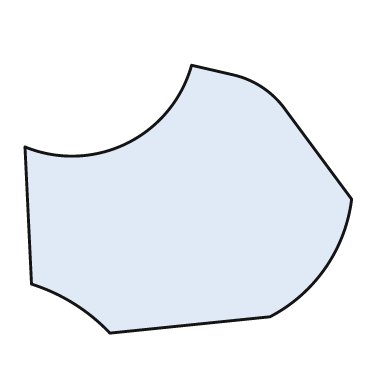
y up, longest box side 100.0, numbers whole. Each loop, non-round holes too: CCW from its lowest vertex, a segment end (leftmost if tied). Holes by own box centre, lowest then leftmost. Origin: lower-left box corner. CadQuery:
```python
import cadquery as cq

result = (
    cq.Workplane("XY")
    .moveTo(26.0, 0.0)
    .lineTo(75.0, 5.0)
    .threePointArc((92.0, 20.0), (100.0, 41.0))
    .lineTo(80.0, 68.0)
    .threePointArc((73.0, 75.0), (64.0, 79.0))
    .lineTo(51.0, 82.0)
    .threePointArc((31.0, 58.0), (0.0, 57.0))
    .lineTo(2.0, 15.0)
    .threePointArc((15.0, 9.0), (26.0, 0.0))
    .close()
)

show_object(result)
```